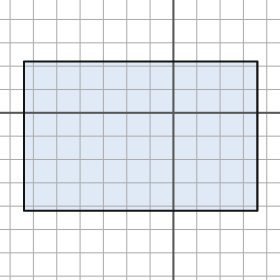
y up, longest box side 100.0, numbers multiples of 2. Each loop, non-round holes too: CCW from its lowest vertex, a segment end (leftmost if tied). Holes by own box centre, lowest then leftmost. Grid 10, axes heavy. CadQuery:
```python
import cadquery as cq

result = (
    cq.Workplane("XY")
    .moveTo(-64.0, -42.0)
    .lineTo(36.0, -42.0)
    .lineTo(36.0, 22.0)
    .lineTo(-64.0, 22.0)
    .close()
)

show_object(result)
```